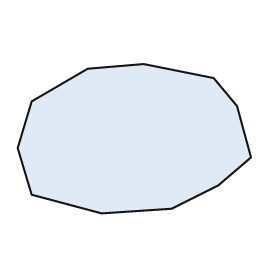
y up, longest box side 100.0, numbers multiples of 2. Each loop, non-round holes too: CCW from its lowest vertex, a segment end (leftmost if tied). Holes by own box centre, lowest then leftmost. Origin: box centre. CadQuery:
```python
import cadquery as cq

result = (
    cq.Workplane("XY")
    .moveTo(-14.0, -32.0)
    .lineTo(16.0, -30.0)
    .lineTo(36.0, -20.0)
    .lineTo(50.0, -8.0)
    .lineTo(44.0, 14.0)
    .lineTo(34.0, 26.0)
    .lineTo(4.0, 32.0)
    .lineTo(-20.0, 30.0)
    .lineTo(-44.0, 16.0)
    .lineTo(-50.0, -4.0)
    .lineTo(-44.0, -24.0)
    .close()
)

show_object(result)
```